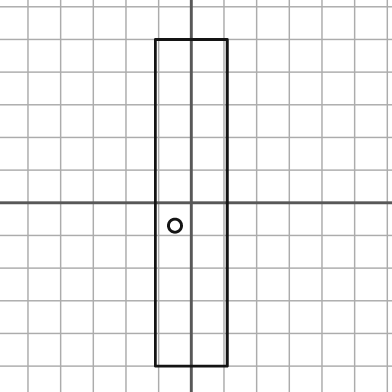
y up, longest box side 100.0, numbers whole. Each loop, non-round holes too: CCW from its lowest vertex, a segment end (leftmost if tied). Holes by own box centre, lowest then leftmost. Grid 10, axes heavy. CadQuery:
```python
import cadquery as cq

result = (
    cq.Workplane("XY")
    .moveTo(-11.0, -50.0)
    .lineTo(11.0, -50.0)
    .lineTo(11.0, 50.0)
    .lineTo(-11.0, 50.0)
    .close()
    .moveTo(-5.0, -7.0)
    .circle(2.0)
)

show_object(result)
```